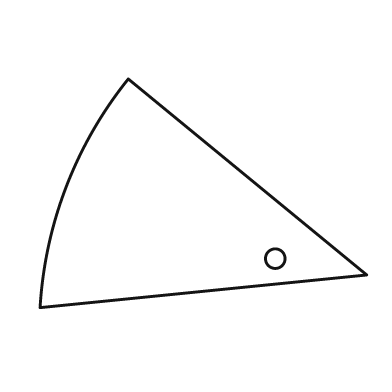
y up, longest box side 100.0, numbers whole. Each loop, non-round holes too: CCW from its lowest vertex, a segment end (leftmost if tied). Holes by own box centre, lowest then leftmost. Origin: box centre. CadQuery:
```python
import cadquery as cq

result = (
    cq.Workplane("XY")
    .moveTo(-50.0, -35.0)
    .lineTo(50.0, -25.0)
    .lineTo(-23.0, 35.0)
    .threePointArc((-42.0, 2.0), (-50.0, -35.0))
    .close()
    .moveTo(22.0, -20.0)
    .circle(3.0)
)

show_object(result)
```